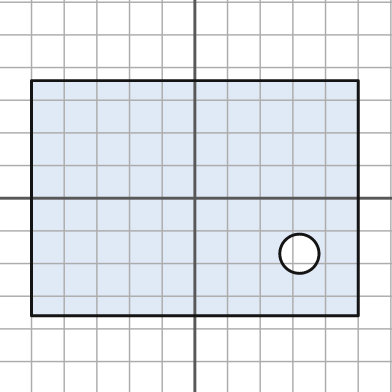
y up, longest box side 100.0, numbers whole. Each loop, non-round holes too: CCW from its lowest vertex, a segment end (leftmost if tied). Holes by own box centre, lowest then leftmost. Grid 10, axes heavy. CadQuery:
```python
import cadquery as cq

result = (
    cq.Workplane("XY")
    .moveTo(-50.0, -36.0)
    .lineTo(50.0, -36.0)
    .lineTo(50.0, 36.0)
    .lineTo(-50.0, 36.0)
    .close()
    .moveTo(32.0, -17.0)
    .circle(6.0)
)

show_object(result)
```